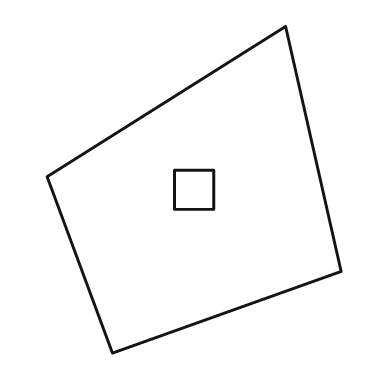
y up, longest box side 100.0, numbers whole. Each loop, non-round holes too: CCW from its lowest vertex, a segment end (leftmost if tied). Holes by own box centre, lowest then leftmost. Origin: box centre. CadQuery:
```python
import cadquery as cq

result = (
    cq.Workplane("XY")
    .moveTo(-25.0, -50.0)
    .lineTo(45.0, -25.0)
    .lineTo(28.0, 50.0)
    .lineTo(-45.0, 4.0)
    .close()
    .moveTo(-6.0, -6.0)
    .lineTo(6.0, -6.0)
    .lineTo(6.0, 6.0)
    .lineTo(-6.0, 6.0)
    .close()
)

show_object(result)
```